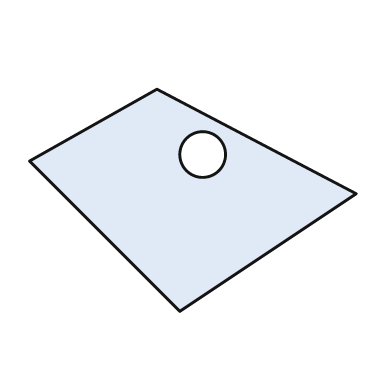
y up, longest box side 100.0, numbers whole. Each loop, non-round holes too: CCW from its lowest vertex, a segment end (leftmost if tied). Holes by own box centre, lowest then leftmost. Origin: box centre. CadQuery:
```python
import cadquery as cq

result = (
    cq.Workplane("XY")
    .moveTo(-4.0, -34.0)
    .lineTo(50.0, 2.0)
    .lineTo(-11.0, 34.0)
    .lineTo(-50.0, 12.0)
    .close()
    .moveTo(3.0, 14.0)
    .circle(7.0)
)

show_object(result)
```